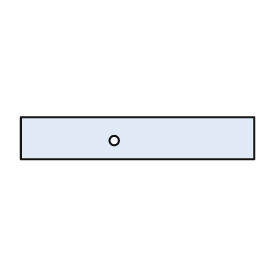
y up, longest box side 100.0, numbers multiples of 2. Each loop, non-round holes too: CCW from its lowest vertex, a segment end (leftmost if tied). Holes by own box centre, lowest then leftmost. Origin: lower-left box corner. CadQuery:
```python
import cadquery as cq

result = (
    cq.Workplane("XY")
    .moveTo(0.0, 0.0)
    .lineTo(100.0, 0.0)
    .lineTo(100.0, 18.0)
    .lineTo(0.0, 18.0)
    .close()
    .moveTo(40.0, 8.0)
    .circle(2.0)
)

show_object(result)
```